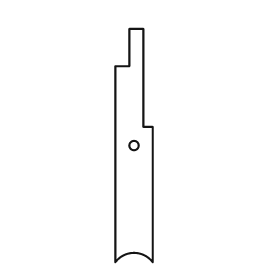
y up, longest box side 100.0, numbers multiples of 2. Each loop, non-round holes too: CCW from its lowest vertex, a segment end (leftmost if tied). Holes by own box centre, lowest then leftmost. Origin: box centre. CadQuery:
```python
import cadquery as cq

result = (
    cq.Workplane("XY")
    .moveTo(-8.0, -50.0)
    .threePointArc((0.0, -46.0), (8.0, -50.0))
    .lineTo(8.0, 8.0)
    .lineTo(4.0, 8.0)
    .lineTo(4.0, 50.0)
    .lineTo(-2.0, 50.0)
    .lineTo(-2.0, 34.0)
    .lineTo(-8.0, 34.0)
    .close()
    .moveTo(0.0, 0.0)
    .circle(2.0)
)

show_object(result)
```